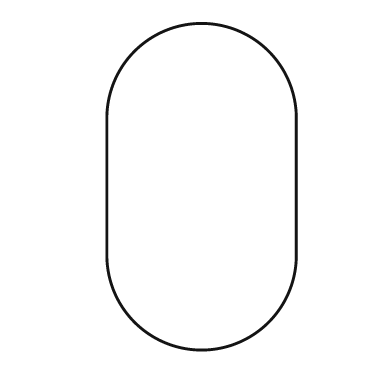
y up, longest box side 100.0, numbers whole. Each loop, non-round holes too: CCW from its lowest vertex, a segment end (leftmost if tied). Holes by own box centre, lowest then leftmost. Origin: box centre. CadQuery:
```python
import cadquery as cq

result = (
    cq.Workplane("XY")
    .moveTo(-29.0, -21.0)
    .threePointArc((0.0, -50.0), (29.0, -21.0))
    .lineTo(29.0, 21.0)
    .threePointArc((0.0, 50.0), (-29.0, 21.0))
    .close()
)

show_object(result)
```